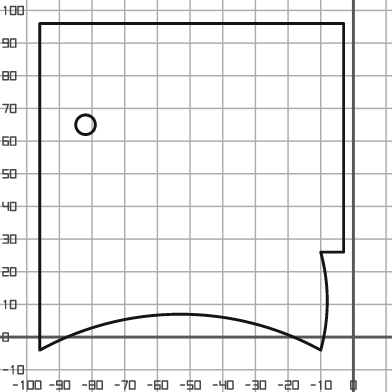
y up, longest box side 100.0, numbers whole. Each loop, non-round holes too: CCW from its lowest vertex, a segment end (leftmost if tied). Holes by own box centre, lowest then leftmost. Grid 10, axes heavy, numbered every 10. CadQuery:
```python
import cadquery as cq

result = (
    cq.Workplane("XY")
    .moveTo(-96.0, -4.0)
    .threePointArc((-53.0, 7.0), (-10.0, -4.0))
    .threePointArc((-8.0, 11.0), (-10.0, 26.0))
    .lineTo(-3.0, 26.0)
    .lineTo(-3.0, 96.0)
    .lineTo(-96.0, 96.0)
    .close()
    .moveTo(-82.0, 65.0)
    .circle(3.0)
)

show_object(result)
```